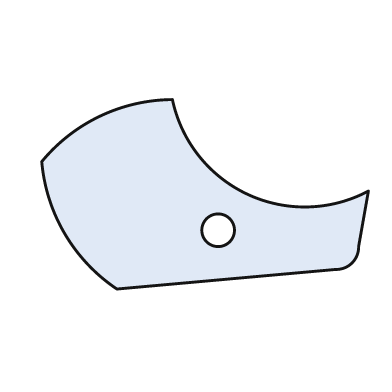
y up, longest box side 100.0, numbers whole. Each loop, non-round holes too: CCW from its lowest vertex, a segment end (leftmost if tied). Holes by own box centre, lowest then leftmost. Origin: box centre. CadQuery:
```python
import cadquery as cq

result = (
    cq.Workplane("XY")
    .moveTo(-27.0, -29.0)
    .lineTo(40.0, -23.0)
    .threePointArc((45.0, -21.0), (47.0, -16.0))
    .lineTo(50.0, 1.0)
    .threePointArc((13.0, 0.0), (-10.0, 29.0))
    .threePointArc((-32.0, 24.0), (-50.0, 10.0))
    .threePointArc((-43.0, -12.0), (-27.0, -29.0))
    .close()
    .moveTo(4.0, -11.0)
    .circle(5.0)
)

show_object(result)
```